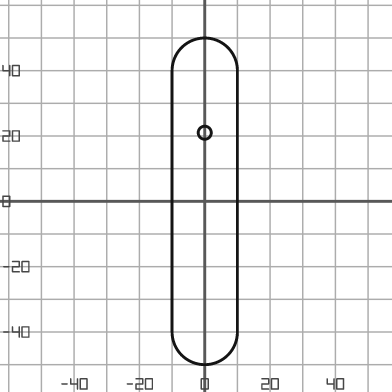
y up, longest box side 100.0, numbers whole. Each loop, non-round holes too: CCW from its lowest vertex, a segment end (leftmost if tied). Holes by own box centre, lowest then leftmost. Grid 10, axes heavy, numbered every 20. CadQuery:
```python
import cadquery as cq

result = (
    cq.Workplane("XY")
    .moveTo(-10.0, -40.0)
    .threePointArc((0.0, -50.0), (10.0, -40.0))
    .lineTo(10.0, 40.0)
    .threePointArc((0.0, 50.0), (-10.0, 40.0))
    .close()
    .moveTo(0.0, 21.0)
    .circle(2.0)
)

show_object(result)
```